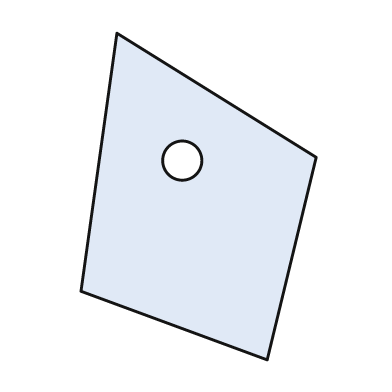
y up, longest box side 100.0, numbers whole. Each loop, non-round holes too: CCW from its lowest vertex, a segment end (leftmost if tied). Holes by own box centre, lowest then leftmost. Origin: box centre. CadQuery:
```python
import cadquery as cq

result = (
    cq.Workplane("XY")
    .moveTo(21.0, -50.0)
    .lineTo(36.0, 12.0)
    .lineTo(-25.0, 50.0)
    .lineTo(-36.0, -29.0)
    .close()
    .moveTo(-5.0, 11.0)
    .circle(6.0)
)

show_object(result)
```